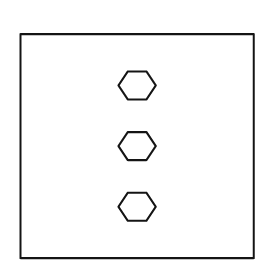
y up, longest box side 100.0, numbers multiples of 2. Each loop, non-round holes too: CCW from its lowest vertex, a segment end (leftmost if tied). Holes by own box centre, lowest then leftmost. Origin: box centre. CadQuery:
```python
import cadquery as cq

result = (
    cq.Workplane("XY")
    .moveTo(-50.0, -48.0)
    .lineTo(50.0, -48.0)
    .lineTo(50.0, 48.0)
    .lineTo(-50.0, 48.0)
    .close()
    .moveTo(-4.0, -32.0)
    .lineTo(4.0, -32.0)
    .lineTo(8.0, -26.0)
    .lineTo(4.0, -20.0)
    .lineTo(-4.0, -20.0)
    .lineTo(-8.0, -26.0)
    .close()
    .moveTo(-4.0, -6.0)
    .lineTo(4.0, -6.0)
    .lineTo(8.0, 0.0)
    .lineTo(4.0, 6.0)
    .lineTo(-4.0, 6.0)
    .lineTo(-8.0, 0.0)
    .close()
    .moveTo(-4.0, 20.0)
    .lineTo(4.0, 20.0)
    .lineTo(8.0, 26.0)
    .lineTo(4.0, 32.0)
    .lineTo(-4.0, 32.0)
    .lineTo(-8.0, 26.0)
    .close()
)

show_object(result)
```